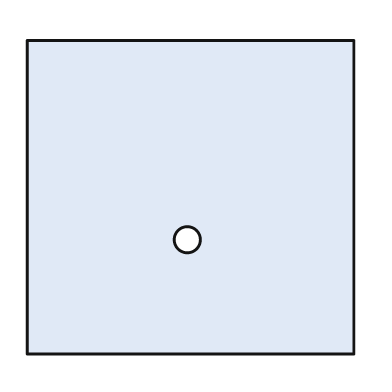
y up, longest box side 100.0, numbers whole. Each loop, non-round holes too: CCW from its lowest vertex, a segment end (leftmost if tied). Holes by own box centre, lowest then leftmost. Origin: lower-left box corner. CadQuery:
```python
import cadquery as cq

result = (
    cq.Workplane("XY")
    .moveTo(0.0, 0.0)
    .lineTo(100.0, 0.0)
    .lineTo(100.0, 96.0)
    .lineTo(0.0, 96.0)
    .close()
    .moveTo(49.0, 35.0)
    .circle(4.0)
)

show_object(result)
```